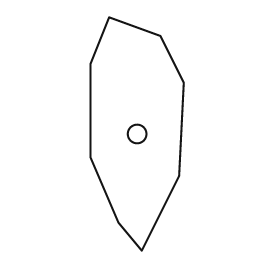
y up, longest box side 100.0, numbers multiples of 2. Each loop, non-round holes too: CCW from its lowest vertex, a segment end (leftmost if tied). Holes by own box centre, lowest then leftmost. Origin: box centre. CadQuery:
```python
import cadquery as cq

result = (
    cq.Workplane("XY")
    .moveTo(2.0, -50.0)
    .lineTo(18.0, -18.0)
    .lineTo(20.0, 22.0)
    .lineTo(10.0, 42.0)
    .lineTo(-12.0, 50.0)
    .lineTo(-20.0, 30.0)
    .lineTo(-20.0, -10.0)
    .lineTo(-8.0, -38.0)
    .close()
    .moveTo(0.0, 0.0)
    .circle(4.0)
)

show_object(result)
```